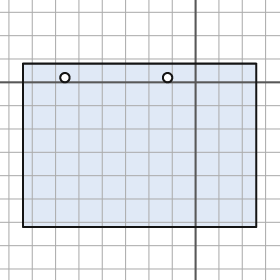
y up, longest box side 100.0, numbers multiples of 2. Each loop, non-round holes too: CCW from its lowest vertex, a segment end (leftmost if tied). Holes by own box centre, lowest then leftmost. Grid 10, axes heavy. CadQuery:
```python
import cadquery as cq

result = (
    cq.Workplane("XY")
    .moveTo(-74.0, -62.0)
    .lineTo(26.0, -62.0)
    .lineTo(26.0, 8.0)
    .lineTo(-74.0, 8.0)
    .close()
    .moveTo(-56.0, 2.0)
    .circle(2.0)
    .moveTo(-12.0, 2.0)
    .circle(2.0)
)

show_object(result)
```